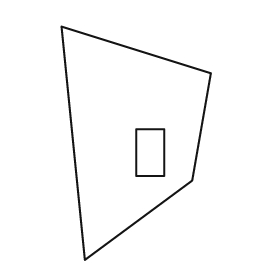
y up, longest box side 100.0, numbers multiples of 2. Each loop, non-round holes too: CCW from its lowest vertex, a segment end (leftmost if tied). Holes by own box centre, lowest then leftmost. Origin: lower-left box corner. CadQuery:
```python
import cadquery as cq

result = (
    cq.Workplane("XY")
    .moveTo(10.0, 0.0)
    .lineTo(56.0, 34.0)
    .lineTo(64.0, 80.0)
    .lineTo(0.0, 100.0)
    .close()
    .moveTo(32.0, 36.0)
    .lineTo(44.0, 36.0)
    .lineTo(44.0, 56.0)
    .lineTo(32.0, 56.0)
    .close()
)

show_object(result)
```